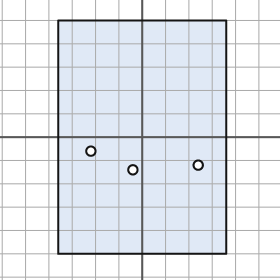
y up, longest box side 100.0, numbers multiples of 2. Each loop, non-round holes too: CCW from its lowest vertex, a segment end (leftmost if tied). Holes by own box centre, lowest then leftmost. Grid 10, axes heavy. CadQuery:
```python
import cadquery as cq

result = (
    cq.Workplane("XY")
    .moveTo(-36.0, -50.0)
    .lineTo(36.0, -50.0)
    .lineTo(36.0, 50.0)
    .lineTo(-36.0, 50.0)
    .close()
    .moveTo(-4.0, -14.0)
    .circle(2.0)
    .moveTo(24.0, -12.0)
    .circle(2.0)
    .moveTo(-22.0, -6.0)
    .circle(2.0)
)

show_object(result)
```